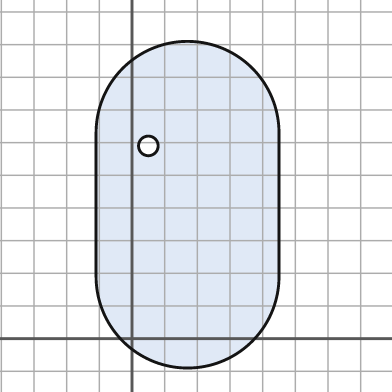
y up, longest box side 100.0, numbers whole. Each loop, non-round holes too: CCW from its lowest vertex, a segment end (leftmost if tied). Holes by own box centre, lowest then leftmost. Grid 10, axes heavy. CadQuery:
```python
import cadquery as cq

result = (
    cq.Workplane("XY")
    .moveTo(-11.0, 19.0)
    .threePointArc((17.0, -9.0), (45.0, 19.0))
    .lineTo(45.0, 63.0)
    .threePointArc((17.0, 91.0), (-11.0, 63.0))
    .close()
    .moveTo(5.0, 59.0)
    .circle(3.0)
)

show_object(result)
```